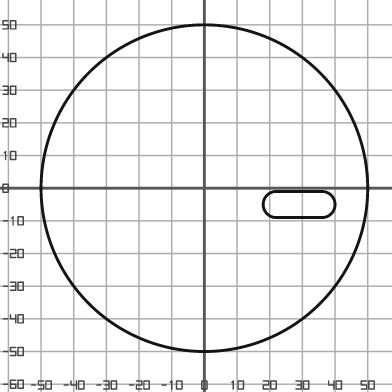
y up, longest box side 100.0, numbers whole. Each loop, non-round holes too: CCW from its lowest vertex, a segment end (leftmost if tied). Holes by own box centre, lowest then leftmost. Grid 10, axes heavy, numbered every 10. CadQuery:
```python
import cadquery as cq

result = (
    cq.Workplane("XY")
    .moveTo(0.0, 0.0)
    .circle(50.0)
    .moveTo(22.0, -9.0)
    .lineTo(36.0, -9.0)
    .threePointArc((40.0, -5.0), (36.0, -1.0))
    .lineTo(22.0, -1.0)
    .threePointArc((18.0, -5.0), (22.0, -9.0))
    .close()
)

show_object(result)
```